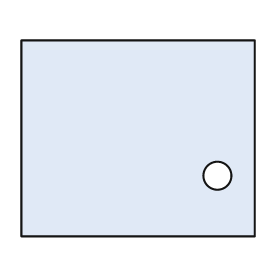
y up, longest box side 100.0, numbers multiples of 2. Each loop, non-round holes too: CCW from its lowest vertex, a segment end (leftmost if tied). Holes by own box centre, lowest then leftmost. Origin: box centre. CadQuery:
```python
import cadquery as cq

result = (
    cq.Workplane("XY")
    .moveTo(-50.0, -42.0)
    .lineTo(50.0, -42.0)
    .lineTo(50.0, 42.0)
    .lineTo(-50.0, 42.0)
    .close()
    .moveTo(34.0, -16.0)
    .circle(6.0)
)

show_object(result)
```